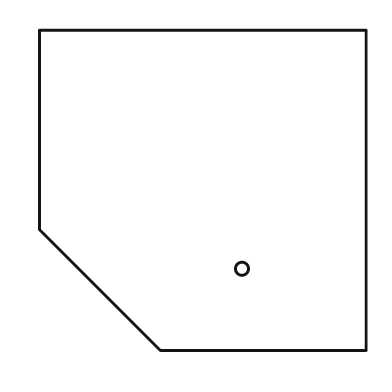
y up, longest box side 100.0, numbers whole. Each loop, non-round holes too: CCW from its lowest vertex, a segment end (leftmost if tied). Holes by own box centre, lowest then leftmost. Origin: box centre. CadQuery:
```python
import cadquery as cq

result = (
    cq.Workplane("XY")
    .moveTo(-13.0, -49.0)
    .lineTo(50.0, -49.0)
    .lineTo(50.0, 49.0)
    .lineTo(-50.0, 49.0)
    .lineTo(-50.0, -12.0)
    .close()
    .moveTo(12.0, -24.0)
    .circle(2.0)
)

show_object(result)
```